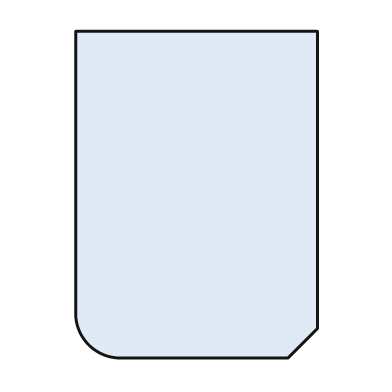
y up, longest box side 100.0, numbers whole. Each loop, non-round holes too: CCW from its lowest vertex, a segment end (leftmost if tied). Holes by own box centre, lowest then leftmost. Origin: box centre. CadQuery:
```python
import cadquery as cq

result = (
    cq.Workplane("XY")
    .moveTo(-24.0, -50.0)
    .lineTo(28.0, -50.0)
    .lineTo(37.0, -41.0)
    .lineTo(37.0, 50.0)
    .lineTo(-37.0, 50.0)
    .lineTo(-37.0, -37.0)
    .threePointArc((-33.0, -46.0), (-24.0, -50.0))
    .close()
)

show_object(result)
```